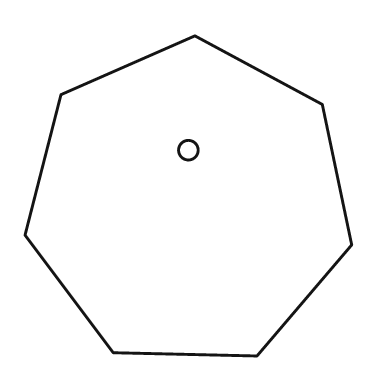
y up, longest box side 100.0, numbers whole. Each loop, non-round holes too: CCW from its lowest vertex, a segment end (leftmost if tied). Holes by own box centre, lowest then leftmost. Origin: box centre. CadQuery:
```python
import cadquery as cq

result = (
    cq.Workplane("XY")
    .moveTo(21.0, -49.0)
    .lineTo(50.0, -15.0)
    .lineTo(41.0, 28.0)
    .lineTo(2.0, 49.0)
    .lineTo(-39.0, 31.0)
    .lineTo(-50.0, -12.0)
    .lineTo(-23.0, -48.0)
    .close()
    .moveTo(0.0, 14.0)
    .circle(3.0)
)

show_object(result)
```